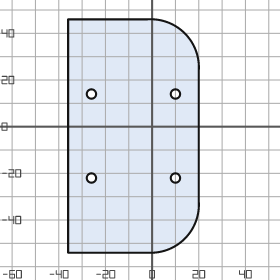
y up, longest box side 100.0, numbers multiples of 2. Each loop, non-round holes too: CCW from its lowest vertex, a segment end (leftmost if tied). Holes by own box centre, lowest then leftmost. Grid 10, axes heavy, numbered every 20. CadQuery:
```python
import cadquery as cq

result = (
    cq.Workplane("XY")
    .moveTo(-36.0, -54.0)
    .lineTo(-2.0, -54.0)
    .threePointArc((14.0, -48.0), (20.0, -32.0))
    .lineTo(20.0, 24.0)
    .threePointArc((14.0, 40.0), (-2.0, 46.0))
    .lineTo(-36.0, 46.0)
    .close()
    .moveTo(-26.0, -22.0)
    .circle(2.0)
    .moveTo(10.0, -22.0)
    .circle(2.0)
    .moveTo(-26.0, 14.0)
    .circle(2.0)
    .moveTo(10.0, 14.0)
    .circle(2.0)
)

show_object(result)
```